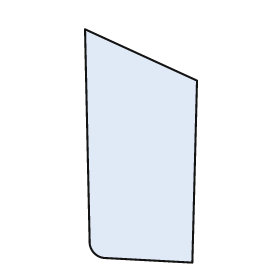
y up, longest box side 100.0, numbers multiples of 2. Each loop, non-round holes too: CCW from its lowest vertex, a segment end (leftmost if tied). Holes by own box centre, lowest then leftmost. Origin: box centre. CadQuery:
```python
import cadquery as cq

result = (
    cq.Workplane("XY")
    .moveTo(22.0, -50.0)
    .lineTo(24.0, 28.0)
    .lineTo(-24.0, 50.0)
    .lineTo(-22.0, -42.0)
    .threePointArc((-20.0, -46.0), (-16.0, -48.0))
    .close()
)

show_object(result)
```